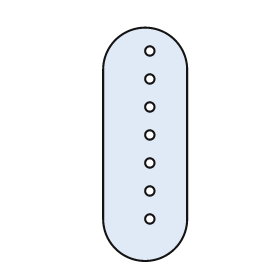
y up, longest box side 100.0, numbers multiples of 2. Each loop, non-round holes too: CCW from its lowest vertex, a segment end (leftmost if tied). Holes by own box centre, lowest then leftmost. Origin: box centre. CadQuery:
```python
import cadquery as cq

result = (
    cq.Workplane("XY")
    .moveTo(-18.0, -32.0)
    .threePointArc((0.0, -50.0), (18.0, -32.0))
    .lineTo(18.0, 32.0)
    .threePointArc((0.0, 50.0), (-18.0, 32.0))
    .close()
    .moveTo(2.0, -32.0)
    .circle(2.0)
    .moveTo(2.0, -20.0)
    .circle(2.0)
    .moveTo(2.0, -8.0)
    .circle(2.0)
    .moveTo(2.0, 4.0)
    .circle(2.0)
    .moveTo(2.0, 16.0)
    .circle(2.0)
    .moveTo(2.0, 28.0)
    .circle(2.0)
    .moveTo(2.0, 40.0)
    .circle(2.0)
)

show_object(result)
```